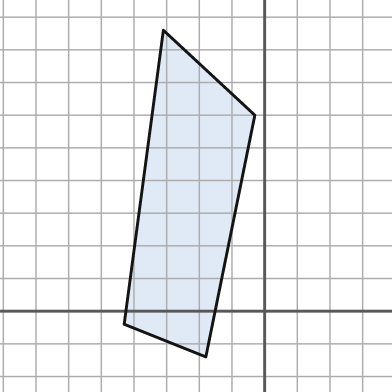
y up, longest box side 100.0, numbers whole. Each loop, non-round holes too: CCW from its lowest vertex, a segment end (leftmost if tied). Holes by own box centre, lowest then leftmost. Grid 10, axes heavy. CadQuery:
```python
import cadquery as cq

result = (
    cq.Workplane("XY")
    .moveTo(-18.0, -14.0)
    .lineTo(-3.0, 60.0)
    .lineTo(-31.0, 86.0)
    .lineTo(-43.0, -4.0)
    .close()
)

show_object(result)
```